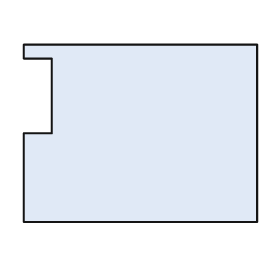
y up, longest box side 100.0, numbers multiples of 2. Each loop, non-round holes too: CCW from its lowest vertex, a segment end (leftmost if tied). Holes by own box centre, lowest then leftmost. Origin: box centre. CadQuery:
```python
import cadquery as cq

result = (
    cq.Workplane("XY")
    .moveTo(-50.0, -38.0)
    .lineTo(50.0, -38.0)
    .lineTo(50.0, 38.0)
    .lineTo(-50.0, 38.0)
    .lineTo(-50.0, 32.0)
    .lineTo(-38.0, 32.0)
    .lineTo(-38.0, 0.0)
    .lineTo(-50.0, 0.0)
    .close()
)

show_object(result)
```